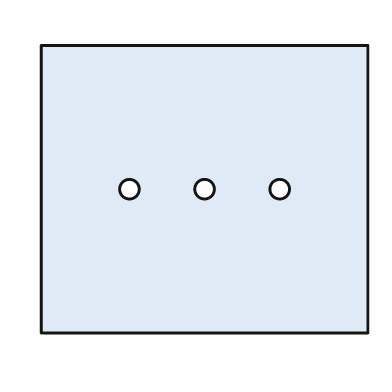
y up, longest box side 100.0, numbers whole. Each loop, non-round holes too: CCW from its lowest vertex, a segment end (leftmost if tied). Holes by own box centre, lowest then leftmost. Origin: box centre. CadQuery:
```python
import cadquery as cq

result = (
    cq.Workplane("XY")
    .moveTo(-50.0, -44.0)
    .lineTo(50.0, -44.0)
    .lineTo(50.0, 44.0)
    .lineTo(-50.0, 44.0)
    .close()
    .moveTo(-23.0, 0.0)
    .circle(3.0)
    .moveTo(0.0, 0.0)
    .circle(3.0)
    .moveTo(23.0, 0.0)
    .circle(3.0)
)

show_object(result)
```